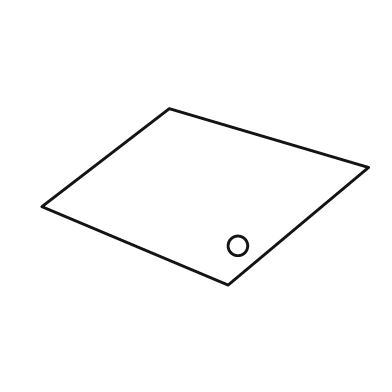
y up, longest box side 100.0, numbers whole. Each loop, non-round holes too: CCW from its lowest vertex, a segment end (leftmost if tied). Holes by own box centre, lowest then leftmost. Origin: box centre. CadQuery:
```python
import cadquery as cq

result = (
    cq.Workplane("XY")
    .moveTo(7.0, -27.0)
    .lineTo(50.0, 9.0)
    .lineTo(-11.0, 27.0)
    .lineTo(-50.0, -3.0)
    .close()
    .moveTo(10.0, -15.0)
    .circle(3.0)
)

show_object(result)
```